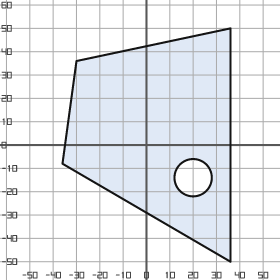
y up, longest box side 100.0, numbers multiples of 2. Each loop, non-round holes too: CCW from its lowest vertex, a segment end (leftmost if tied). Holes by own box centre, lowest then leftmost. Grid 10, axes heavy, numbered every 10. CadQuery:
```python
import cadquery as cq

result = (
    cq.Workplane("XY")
    .moveTo(36.0, -50.0)
    .lineTo(36.0, 50.0)
    .lineTo(-30.0, 36.0)
    .lineTo(-36.0, -8.0)
    .close()
    .moveTo(20.0, -14.0)
    .circle(8.0)
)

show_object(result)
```